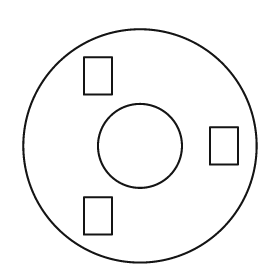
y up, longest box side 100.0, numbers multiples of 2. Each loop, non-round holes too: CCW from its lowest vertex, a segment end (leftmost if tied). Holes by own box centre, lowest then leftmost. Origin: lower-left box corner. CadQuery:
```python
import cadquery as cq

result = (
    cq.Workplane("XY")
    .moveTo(50.0, 50.0)
    .circle(50.0)
    .moveTo(26.0, 12.0)
    .lineTo(38.0, 12.0)
    .lineTo(38.0, 28.0)
    .lineTo(26.0, 28.0)
    .close()
    .moveTo(50.0, 50.0)
    .circle(18.0)
    .moveTo(80.0, 42.0)
    .lineTo(92.0, 42.0)
    .lineTo(92.0, 58.0)
    .lineTo(80.0, 58.0)
    .close()
    .moveTo(26.0, 72.0)
    .lineTo(38.0, 72.0)
    .lineTo(38.0, 88.0)
    .lineTo(26.0, 88.0)
    .close()
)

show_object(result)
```